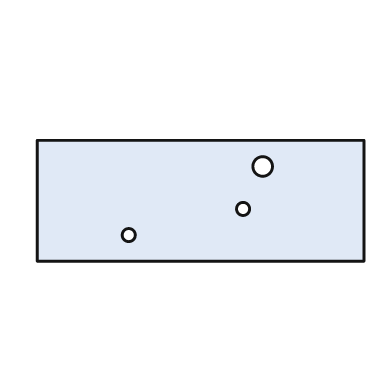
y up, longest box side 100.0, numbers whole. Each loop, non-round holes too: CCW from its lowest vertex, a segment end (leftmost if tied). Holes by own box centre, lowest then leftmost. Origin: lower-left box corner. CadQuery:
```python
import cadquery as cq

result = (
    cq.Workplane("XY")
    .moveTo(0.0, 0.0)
    .lineTo(100.0, 0.0)
    .lineTo(100.0, 37.0)
    .lineTo(0.0, 37.0)
    .close()
    .moveTo(28.0, 8.0)
    .circle(2.0)
    .moveTo(63.0, 16.0)
    .circle(2.0)
    .moveTo(69.0, 29.0)
    .circle(3.0)
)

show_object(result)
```